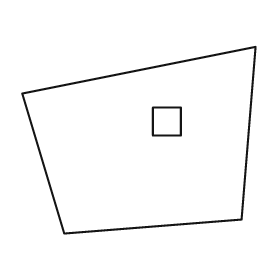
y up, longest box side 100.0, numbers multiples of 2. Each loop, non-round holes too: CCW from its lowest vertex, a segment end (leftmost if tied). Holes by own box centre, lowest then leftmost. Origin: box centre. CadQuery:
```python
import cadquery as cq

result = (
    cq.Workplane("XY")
    .moveTo(-32.0, -40.0)
    .lineTo(44.0, -34.0)
    .lineTo(50.0, 40.0)
    .lineTo(-50.0, 20.0)
    .close()
    .moveTo(6.0, 2.0)
    .lineTo(18.0, 2.0)
    .lineTo(18.0, 14.0)
    .lineTo(6.0, 14.0)
    .close()
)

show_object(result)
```